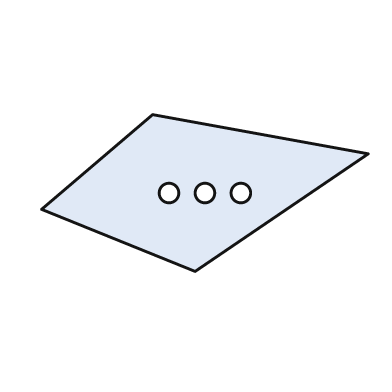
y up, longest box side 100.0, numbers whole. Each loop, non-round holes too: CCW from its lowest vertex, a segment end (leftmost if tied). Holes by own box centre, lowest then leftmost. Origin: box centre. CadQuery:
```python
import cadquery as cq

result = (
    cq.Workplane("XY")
    .moveTo(-3.0, -24.0)
    .lineTo(50.0, 12.0)
    .lineTo(-16.0, 24.0)
    .lineTo(-50.0, -5.0)
    .close()
    .moveTo(-11.0, 0.0)
    .circle(3.0)
    .moveTo(0.0, 0.0)
    .circle(3.0)
    .moveTo(11.0, 0.0)
    .circle(3.0)
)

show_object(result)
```